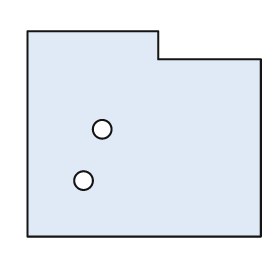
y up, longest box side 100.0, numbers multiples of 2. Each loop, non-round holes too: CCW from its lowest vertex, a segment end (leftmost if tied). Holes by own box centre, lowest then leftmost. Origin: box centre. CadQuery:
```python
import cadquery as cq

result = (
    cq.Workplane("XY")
    .moveTo(-50.0, -44.0)
    .lineTo(50.0, -44.0)
    .lineTo(50.0, 32.0)
    .lineTo(6.0, 32.0)
    .lineTo(6.0, 44.0)
    .lineTo(-50.0, 44.0)
    .close()
    .moveTo(-26.0, -20.0)
    .circle(4.0)
    .moveTo(-18.0, 2.0)
    .circle(4.0)
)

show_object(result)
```